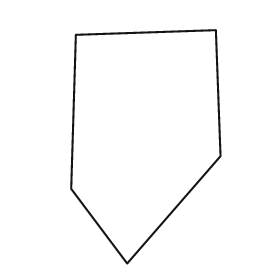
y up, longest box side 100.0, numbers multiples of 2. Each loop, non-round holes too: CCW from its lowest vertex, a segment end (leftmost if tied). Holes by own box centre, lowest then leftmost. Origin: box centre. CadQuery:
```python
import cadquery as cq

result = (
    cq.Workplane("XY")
    .moveTo(-8.0, -50.0)
    .lineTo(32.0, -4.0)
    .lineTo(30.0, 50.0)
    .lineTo(-30.0, 48.0)
    .lineTo(-32.0, -18.0)
    .close()
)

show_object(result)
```